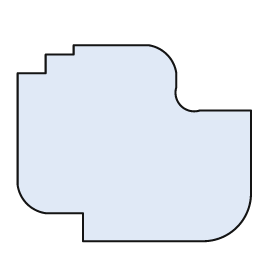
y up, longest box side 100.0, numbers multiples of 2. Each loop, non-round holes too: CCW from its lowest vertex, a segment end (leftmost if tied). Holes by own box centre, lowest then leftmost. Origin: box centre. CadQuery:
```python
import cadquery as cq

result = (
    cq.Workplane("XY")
    .moveTo(-22.0, -42.0)
    .lineTo(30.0, -42.0)
    .threePointArc((44.0, -36.0), (50.0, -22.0))
    .lineTo(50.0, 14.0)
    .lineTo(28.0, 14.0)
    .threePointArc((20.0, 16.0), (18.0, 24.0))
    .lineTo(18.0, 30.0)
    .threePointArc((14.0, 38.0), (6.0, 42.0))
    .lineTo(-26.0, 42.0)
    .lineTo(-26.0, 38.0)
    .lineTo(-38.0, 38.0)
    .lineTo(-38.0, 30.0)
    .lineTo(-50.0, 30.0)
    .lineTo(-50.0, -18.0)
    .threePointArc((-46.0, -26.0), (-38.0, -30.0))
    .lineTo(-22.0, -30.0)
    .close()
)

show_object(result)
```